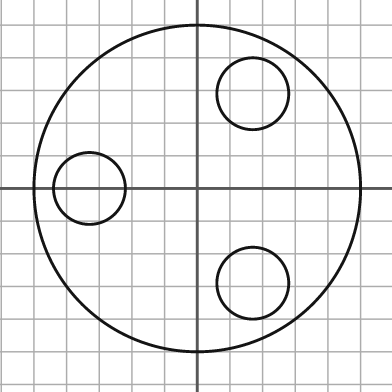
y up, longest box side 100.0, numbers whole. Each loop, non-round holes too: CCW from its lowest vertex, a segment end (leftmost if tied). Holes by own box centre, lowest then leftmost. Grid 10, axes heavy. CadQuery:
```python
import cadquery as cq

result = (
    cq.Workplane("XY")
    .moveTo(0.0, 0.0)
    .circle(50.0)
    .moveTo(17.0, -29.0)
    .circle(11.0)
    .moveTo(-33.0, 0.0)
    .circle(11.0)
    .moveTo(17.0, 29.0)
    .circle(11.0)
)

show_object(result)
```